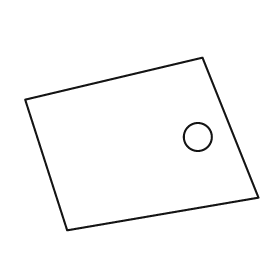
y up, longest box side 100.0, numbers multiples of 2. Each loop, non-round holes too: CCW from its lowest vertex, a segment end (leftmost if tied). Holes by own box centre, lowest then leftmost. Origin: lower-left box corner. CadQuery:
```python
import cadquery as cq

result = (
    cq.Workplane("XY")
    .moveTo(18.0, 0.0)
    .lineTo(100.0, 14.0)
    .lineTo(76.0, 74.0)
    .lineTo(0.0, 56.0)
    .close()
    .moveTo(74.0, 40.0)
    .circle(6.0)
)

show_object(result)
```